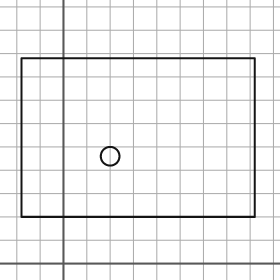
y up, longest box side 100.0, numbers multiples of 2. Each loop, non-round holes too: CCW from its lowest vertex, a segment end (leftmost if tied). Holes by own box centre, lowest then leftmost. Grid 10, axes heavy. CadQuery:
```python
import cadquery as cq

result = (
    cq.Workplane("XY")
    .moveTo(-18.0, 20.0)
    .lineTo(82.0, 20.0)
    .lineTo(82.0, 88.0)
    .lineTo(-18.0, 88.0)
    .close()
    .moveTo(20.0, 46.0)
    .circle(4.0)
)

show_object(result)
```